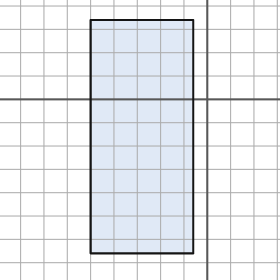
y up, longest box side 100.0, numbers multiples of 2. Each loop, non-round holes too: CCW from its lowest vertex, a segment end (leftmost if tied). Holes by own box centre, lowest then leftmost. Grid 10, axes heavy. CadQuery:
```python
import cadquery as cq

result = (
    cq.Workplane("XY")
    .moveTo(-50.0, -66.0)
    .lineTo(-6.0, -66.0)
    .lineTo(-6.0, 34.0)
    .lineTo(-50.0, 34.0)
    .close()
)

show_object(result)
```